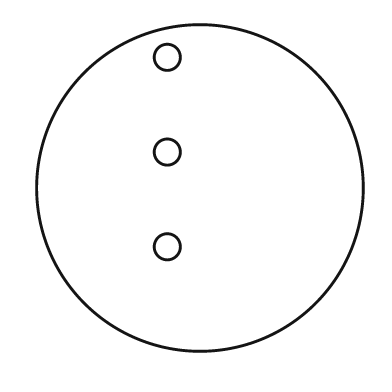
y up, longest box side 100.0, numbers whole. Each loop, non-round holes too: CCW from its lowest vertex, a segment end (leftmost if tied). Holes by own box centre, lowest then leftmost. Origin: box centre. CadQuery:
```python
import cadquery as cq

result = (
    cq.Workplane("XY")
    .moveTo(0.0, 0.0)
    .circle(50.0)
    .moveTo(-10.0, -18.0)
    .circle(4.0)
    .moveTo(-10.0, 11.0)
    .circle(4.0)
    .moveTo(-10.0, 40.0)
    .circle(4.0)
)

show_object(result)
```